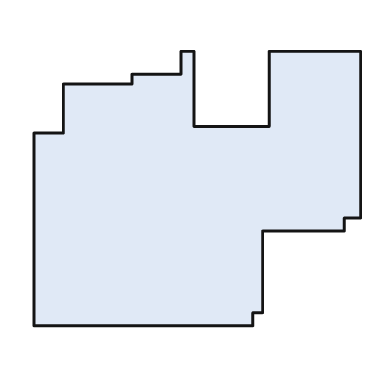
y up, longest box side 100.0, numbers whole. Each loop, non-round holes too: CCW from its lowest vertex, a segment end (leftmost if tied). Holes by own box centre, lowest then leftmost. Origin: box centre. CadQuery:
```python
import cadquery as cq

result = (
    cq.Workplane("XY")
    .moveTo(-50.0, -42.0)
    .lineTo(17.0, -42.0)
    .lineTo(17.0, -38.0)
    .lineTo(20.0, -38.0)
    .lineTo(20.0, -13.0)
    .lineTo(45.0, -13.0)
    .lineTo(45.0, -9.0)
    .lineTo(50.0, -9.0)
    .lineTo(50.0, 42.0)
    .lineTo(22.0, 42.0)
    .lineTo(22.0, 19.0)
    .lineTo(-1.0, 19.0)
    .lineTo(-1.0, 42.0)
    .lineTo(-5.0, 42.0)
    .lineTo(-5.0, 35.0)
    .lineTo(-20.0, 35.0)
    .lineTo(-20.0, 32.0)
    .lineTo(-41.0, 32.0)
    .lineTo(-41.0, 17.0)
    .lineTo(-50.0, 17.0)
    .close()
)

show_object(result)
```